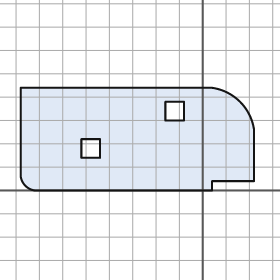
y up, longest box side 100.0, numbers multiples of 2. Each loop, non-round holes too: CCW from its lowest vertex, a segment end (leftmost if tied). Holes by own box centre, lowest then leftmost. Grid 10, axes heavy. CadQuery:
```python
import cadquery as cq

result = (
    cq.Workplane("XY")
    .moveTo(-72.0, 0.0)
    .lineTo(4.0, 0.0)
    .lineTo(4.0, 4.0)
    .lineTo(22.0, 4.0)
    .lineTo(22.0, 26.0)
    .threePointArc((16.0, 38.0), (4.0, 44.0))
    .lineTo(-78.0, 44.0)
    .lineTo(-78.0, 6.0)
    .threePointArc((-76.0, 2.0), (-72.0, 0.0))
    .close()
    .moveTo(-52.0, 14.0)
    .lineTo(-44.0, 14.0)
    .lineTo(-44.0, 22.0)
    .lineTo(-52.0, 22.0)
    .close()
    .moveTo(-16.0, 30.0)
    .lineTo(-8.0, 30.0)
    .lineTo(-8.0, 38.0)
    .lineTo(-16.0, 38.0)
    .close()
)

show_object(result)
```